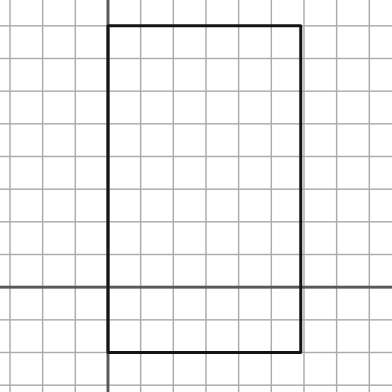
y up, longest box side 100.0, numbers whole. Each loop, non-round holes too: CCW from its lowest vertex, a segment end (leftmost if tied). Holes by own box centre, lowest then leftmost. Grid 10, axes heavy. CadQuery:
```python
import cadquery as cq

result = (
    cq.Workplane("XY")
    .moveTo(0.0, -20.0)
    .lineTo(59.0, -20.0)
    .lineTo(59.0, 80.0)
    .lineTo(0.0, 80.0)
    .close()
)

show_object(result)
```